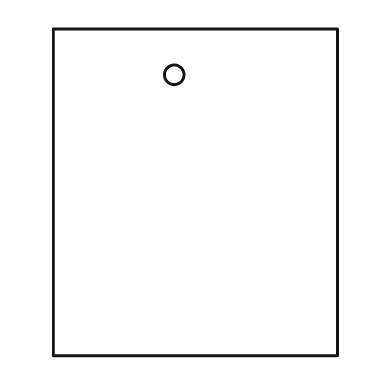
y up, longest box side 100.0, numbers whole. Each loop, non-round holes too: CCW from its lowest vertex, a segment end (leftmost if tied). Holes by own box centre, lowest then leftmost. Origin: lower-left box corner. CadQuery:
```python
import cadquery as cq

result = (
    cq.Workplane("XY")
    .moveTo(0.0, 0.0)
    .lineTo(87.0, 0.0)
    .lineTo(87.0, 100.0)
    .lineTo(0.0, 100.0)
    .close()
    .moveTo(37.0, 86.0)
    .circle(3.0)
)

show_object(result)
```